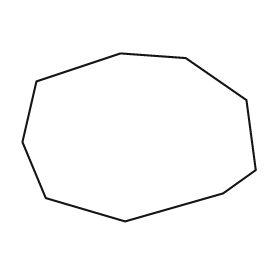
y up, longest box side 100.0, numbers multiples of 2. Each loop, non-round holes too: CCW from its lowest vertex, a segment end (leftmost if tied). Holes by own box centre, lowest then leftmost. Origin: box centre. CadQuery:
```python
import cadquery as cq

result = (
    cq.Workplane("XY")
    .moveTo(-6.0, -36.0)
    .lineTo(36.0, -24.0)
    .lineTo(50.0, -14.0)
    .lineTo(46.0, 16.0)
    .lineTo(20.0, 34.0)
    .lineTo(-8.0, 36.0)
    .lineTo(-44.0, 24.0)
    .lineTo(-50.0, -2.0)
    .lineTo(-40.0, -26.0)
    .close()
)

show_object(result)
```